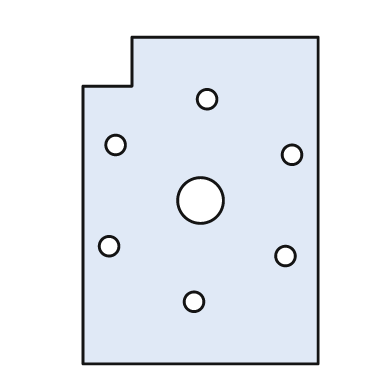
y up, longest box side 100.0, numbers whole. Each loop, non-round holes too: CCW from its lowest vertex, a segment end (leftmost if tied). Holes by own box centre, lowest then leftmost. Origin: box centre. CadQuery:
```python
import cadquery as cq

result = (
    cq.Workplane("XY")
    .moveTo(-36.0, -50.0)
    .lineTo(36.0, -50.0)
    .lineTo(36.0, 50.0)
    .lineTo(-21.0, 50.0)
    .lineTo(-21.0, 35.0)
    .lineTo(-36.0, 35.0)
    .close()
    .moveTo(-2.0, -31.0)
    .circle(3.0)
    .moveTo(26.0, -17.0)
    .circle(3.0)
    .moveTo(-28.0, -14.0)
    .circle(3.0)
    .moveTo(0.0, 0.0)
    .circle(7.0)
    .moveTo(28.0, 14.0)
    .circle(3.0)
    .moveTo(-26.0, 17.0)
    .circle(3.0)
    .moveTo(2.0, 31.0)
    .circle(3.0)
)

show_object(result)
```